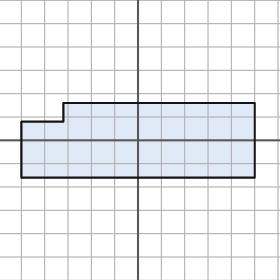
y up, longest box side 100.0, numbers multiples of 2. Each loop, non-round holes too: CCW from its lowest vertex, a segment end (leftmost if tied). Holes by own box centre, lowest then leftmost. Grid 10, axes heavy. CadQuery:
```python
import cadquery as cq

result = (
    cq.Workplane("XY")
    .moveTo(-50.0, -16.0)
    .lineTo(50.0, -16.0)
    .lineTo(50.0, 16.0)
    .lineTo(-32.0, 16.0)
    .lineTo(-32.0, 8.0)
    .lineTo(-50.0, 8.0)
    .close()
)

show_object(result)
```